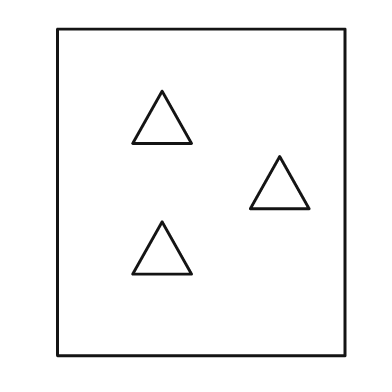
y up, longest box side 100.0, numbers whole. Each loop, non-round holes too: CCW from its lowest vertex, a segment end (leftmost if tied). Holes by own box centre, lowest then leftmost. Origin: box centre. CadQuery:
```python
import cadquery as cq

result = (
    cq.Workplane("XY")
    .moveTo(-44.0, -50.0)
    .lineTo(44.0, -50.0)
    .lineTo(44.0, 50.0)
    .lineTo(-44.0, 50.0)
    .close()
    .moveTo(-21.0, -25.0)
    .lineTo(-3.0, -25.0)
    .lineTo(-12.0, -9.0)
    .close()
    .moveTo(15.0, -5.0)
    .lineTo(33.0, -5.0)
    .lineTo(24.0, 11.0)
    .close()
    .moveTo(-21.0, 15.0)
    .lineTo(-3.0, 15.0)
    .lineTo(-12.0, 31.0)
    .close()
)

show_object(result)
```